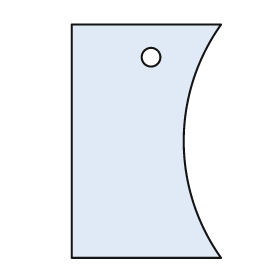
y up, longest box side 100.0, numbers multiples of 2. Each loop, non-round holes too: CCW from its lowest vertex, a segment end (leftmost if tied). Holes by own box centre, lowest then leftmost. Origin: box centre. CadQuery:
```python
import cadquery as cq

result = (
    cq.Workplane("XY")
    .moveTo(-32.0, -50.0)
    .lineTo(32.0, -50.0)
    .threePointArc((16.0, 0.0), (32.0, 50.0))
    .lineTo(-32.0, 50.0)
    .close()
    .moveTo(2.0, 36.0)
    .circle(4.0)
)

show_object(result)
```